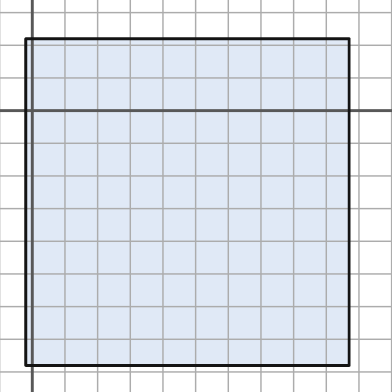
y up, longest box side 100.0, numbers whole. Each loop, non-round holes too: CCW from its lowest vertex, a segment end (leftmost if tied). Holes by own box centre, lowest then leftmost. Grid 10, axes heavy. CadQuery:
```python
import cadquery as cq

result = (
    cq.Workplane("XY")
    .moveTo(-2.0, -78.0)
    .lineTo(97.0, -78.0)
    .lineTo(97.0, 22.0)
    .lineTo(-2.0, 22.0)
    .close()
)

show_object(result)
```